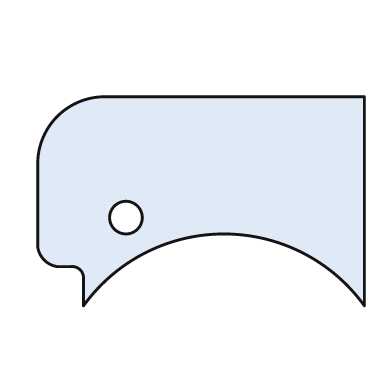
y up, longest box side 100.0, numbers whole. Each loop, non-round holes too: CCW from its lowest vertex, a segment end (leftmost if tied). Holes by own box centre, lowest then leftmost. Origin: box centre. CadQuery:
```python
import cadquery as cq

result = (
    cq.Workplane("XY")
    .moveTo(-36.0, -32.0)
    .threePointArc((7.0, -10.0), (50.0, -32.0))
    .lineTo(50.0, 32.0)
    .lineTo(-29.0, 32.0)
    .threePointArc((-44.0, 26.0), (-50.0, 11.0))
    .lineTo(-50.0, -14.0)
    .threePointArc((-48.0, -18.0), (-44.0, -20.0))
    .lineTo(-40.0, -20.0)
    .threePointArc((-37.0, -21.0), (-36.0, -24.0))
    .close()
    .moveTo(-23.0, -5.0)
    .circle(5.0)
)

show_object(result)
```